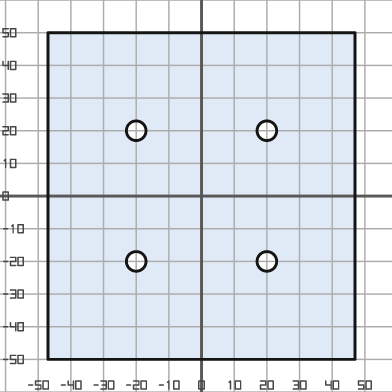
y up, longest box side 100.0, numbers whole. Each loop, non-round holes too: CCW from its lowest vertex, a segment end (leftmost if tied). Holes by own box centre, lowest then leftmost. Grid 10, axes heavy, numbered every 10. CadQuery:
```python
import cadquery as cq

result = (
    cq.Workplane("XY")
    .moveTo(-47.0, -50.0)
    .lineTo(47.0, -50.0)
    .lineTo(47.0, 50.0)
    .lineTo(-47.0, 50.0)
    .close()
    .moveTo(-20.0, -20.0)
    .circle(3.0)
    .moveTo(20.0, -20.0)
    .circle(3.0)
    .moveTo(-20.0, 20.0)
    .circle(3.0)
    .moveTo(20.0, 20.0)
    .circle(3.0)
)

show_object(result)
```